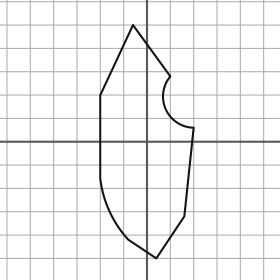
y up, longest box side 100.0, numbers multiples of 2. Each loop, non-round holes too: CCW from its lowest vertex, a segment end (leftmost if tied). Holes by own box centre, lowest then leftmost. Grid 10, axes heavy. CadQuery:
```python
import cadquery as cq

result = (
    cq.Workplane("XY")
    .moveTo(4.0, -50.0)
    .lineTo(16.0, -32.0)
    .lineTo(20.0, 6.0)
    .threePointArc((8.0, 14.0), (10.0, 28.0))
    .lineTo(-6.0, 50.0)
    .lineTo(-20.0, 20.0)
    .lineTo(-20.0, -16.0)
    .threePointArc((-16.0, -30.0), (-8.0, -42.0))
    .close()
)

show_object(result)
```